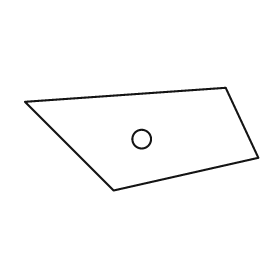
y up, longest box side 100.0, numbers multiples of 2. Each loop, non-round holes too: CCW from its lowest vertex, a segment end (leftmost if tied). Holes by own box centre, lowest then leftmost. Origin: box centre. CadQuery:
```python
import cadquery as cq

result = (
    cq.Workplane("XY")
    .moveTo(-12.0, -22.0)
    .lineTo(50.0, -8.0)
    .lineTo(36.0, 22.0)
    .lineTo(-50.0, 16.0)
    .close()
    .moveTo(0.0, 0.0)
    .circle(4.0)
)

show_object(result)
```